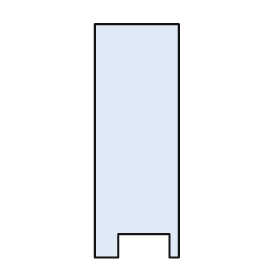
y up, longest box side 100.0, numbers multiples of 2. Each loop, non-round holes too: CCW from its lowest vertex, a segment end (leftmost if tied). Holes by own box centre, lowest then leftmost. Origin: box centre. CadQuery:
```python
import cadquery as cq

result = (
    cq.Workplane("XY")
    .moveTo(-18.0, -50.0)
    .lineTo(-8.0, -50.0)
    .lineTo(-8.0, -40.0)
    .lineTo(14.0, -40.0)
    .lineTo(14.0, -50.0)
    .lineTo(18.0, -50.0)
    .lineTo(18.0, 50.0)
    .lineTo(-18.0, 50.0)
    .close()
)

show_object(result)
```